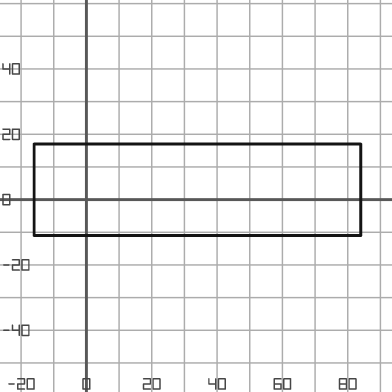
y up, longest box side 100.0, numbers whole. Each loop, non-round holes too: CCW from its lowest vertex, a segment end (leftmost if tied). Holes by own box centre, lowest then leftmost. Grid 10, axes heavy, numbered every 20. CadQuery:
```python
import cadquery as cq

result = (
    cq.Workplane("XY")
    .moveTo(-16.0, -11.0)
    .lineTo(84.0, -11.0)
    .lineTo(84.0, 17.0)
    .lineTo(-16.0, 17.0)
    .close()
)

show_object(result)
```